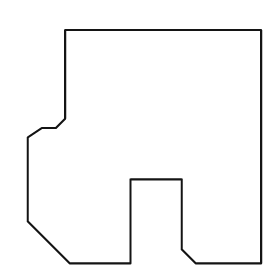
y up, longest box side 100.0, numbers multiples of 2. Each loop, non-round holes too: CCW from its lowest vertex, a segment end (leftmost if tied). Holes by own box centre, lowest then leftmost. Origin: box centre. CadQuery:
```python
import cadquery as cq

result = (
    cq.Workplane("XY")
    .moveTo(-32.0, -50.0)
    .lineTo(-6.0, -50.0)
    .lineTo(-6.0, -14.0)
    .lineTo(16.0, -14.0)
    .lineTo(16.0, -44.0)
    .lineTo(22.0, -50.0)
    .lineTo(50.0, -50.0)
    .lineTo(50.0, 50.0)
    .lineTo(-34.0, 50.0)
    .lineTo(-34.0, 12.0)
    .lineTo(-38.0, 8.0)
    .lineTo(-44.0, 8.0)
    .lineTo(-50.0, 4.0)
    .lineTo(-50.0, -32.0)
    .close()
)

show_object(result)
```